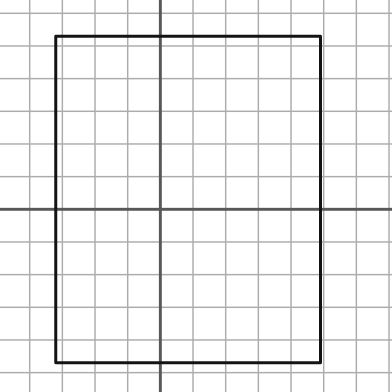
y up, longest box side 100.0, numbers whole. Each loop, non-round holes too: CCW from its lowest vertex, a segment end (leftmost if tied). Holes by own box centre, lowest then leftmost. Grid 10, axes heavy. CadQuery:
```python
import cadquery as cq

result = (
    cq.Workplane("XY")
    .moveTo(-32.0, -47.0)
    .lineTo(49.0, -47.0)
    .lineTo(49.0, 53.0)
    .lineTo(-32.0, 53.0)
    .close()
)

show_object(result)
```